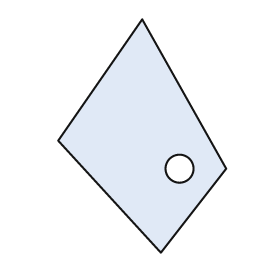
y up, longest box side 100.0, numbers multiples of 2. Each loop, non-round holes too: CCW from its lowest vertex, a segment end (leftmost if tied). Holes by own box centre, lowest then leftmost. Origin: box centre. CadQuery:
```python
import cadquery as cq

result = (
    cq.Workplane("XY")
    .moveTo(8.0, -50.0)
    .lineTo(36.0, -14.0)
    .lineTo(0.0, 50.0)
    .lineTo(-36.0, -2.0)
    .close()
    .moveTo(16.0, -14.0)
    .circle(6.0)
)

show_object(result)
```